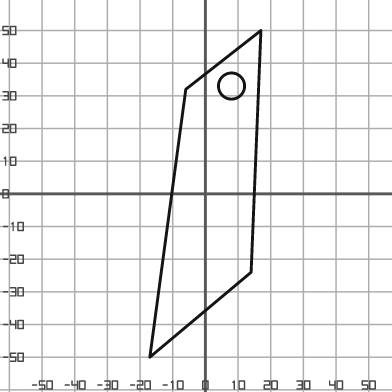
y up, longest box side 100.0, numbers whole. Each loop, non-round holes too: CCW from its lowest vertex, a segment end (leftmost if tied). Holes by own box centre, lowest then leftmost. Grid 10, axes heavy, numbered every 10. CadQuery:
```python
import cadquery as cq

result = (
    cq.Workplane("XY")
    .moveTo(-17.0, -50.0)
    .lineTo(14.0, -24.0)
    .lineTo(17.0, 50.0)
    .lineTo(-6.0, 32.0)
    .close()
    .moveTo(8.0, 33.0)
    .circle(4.0)
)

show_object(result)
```